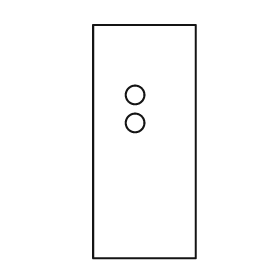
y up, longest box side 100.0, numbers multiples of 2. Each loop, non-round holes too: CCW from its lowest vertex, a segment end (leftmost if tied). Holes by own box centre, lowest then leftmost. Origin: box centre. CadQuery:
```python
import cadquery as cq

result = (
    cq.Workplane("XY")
    .moveTo(-22.0, -50.0)
    .lineTo(22.0, -50.0)
    .lineTo(22.0, 50.0)
    .lineTo(-22.0, 50.0)
    .close()
    .moveTo(-4.0, 8.0)
    .circle(4.0)
    .moveTo(-4.0, 20.0)
    .circle(4.0)
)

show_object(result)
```